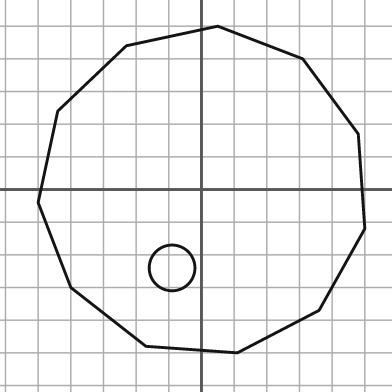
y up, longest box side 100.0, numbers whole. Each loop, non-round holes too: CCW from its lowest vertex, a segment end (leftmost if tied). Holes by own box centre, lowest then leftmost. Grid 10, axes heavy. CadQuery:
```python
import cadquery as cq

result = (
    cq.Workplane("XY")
    .moveTo(11.0, -50.0)
    .lineTo(36.0, -37.0)
    .lineTo(50.0, -12.0)
    .lineTo(48.0, 17.0)
    .lineTo(31.0, 40.0)
    .lineTo(5.0, 50.0)
    .lineTo(-23.0, 44.0)
    .lineTo(-44.0, 24.0)
    .lineTo(-50.0, -4.0)
    .lineTo(-40.0, -30.0)
    .lineTo(-17.0, -48.0)
    .close()
    .moveTo(-9.0, -24.0)
    .circle(7.0)
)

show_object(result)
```